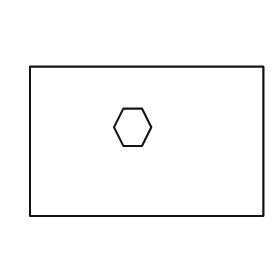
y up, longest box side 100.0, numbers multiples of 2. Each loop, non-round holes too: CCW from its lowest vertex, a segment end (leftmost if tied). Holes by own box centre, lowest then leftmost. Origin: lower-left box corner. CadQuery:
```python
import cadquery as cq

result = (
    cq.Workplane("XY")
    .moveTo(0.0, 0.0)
    .lineTo(100.0, 0.0)
    .lineTo(100.0, 64.0)
    .lineTo(0.0, 64.0)
    .close()
    .moveTo(40.0, 30.0)
    .lineTo(48.0, 30.0)
    .lineTo(52.0, 38.0)
    .lineTo(48.0, 46.0)
    .lineTo(40.0, 46.0)
    .lineTo(36.0, 38.0)
    .close()
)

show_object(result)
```